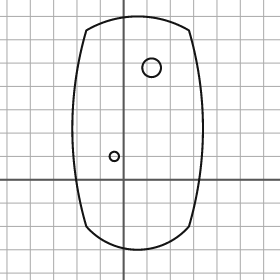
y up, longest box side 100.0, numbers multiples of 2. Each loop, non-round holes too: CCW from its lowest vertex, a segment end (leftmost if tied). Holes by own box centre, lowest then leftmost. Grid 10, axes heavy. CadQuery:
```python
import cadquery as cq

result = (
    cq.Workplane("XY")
    .moveTo(-16.0, -20.0)
    .threePointArc((6.0, -30.0), (28.0, -20.0))
    .threePointArc((34.0, 22.0), (28.0, 64.0))
    .threePointArc((6.0, 70.0), (-16.0, 64.0))
    .threePointArc((-22.0, 22.0), (-16.0, -20.0))
    .close()
    .moveTo(-4.0, 10.0)
    .circle(2.0)
    .moveTo(12.0, 48.0)
    .circle(4.0)
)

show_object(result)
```